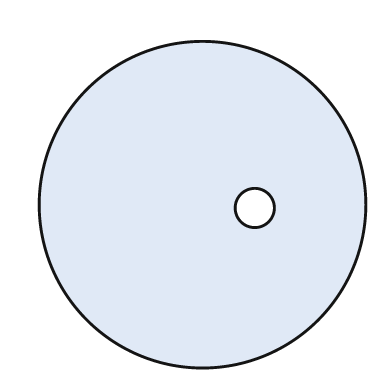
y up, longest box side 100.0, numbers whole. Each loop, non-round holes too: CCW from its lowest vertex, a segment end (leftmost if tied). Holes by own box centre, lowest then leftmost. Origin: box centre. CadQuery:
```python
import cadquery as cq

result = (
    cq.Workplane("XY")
    .moveTo(0.0, 0.0)
    .circle(50.0)
    .moveTo(16.0, -1.0)
    .circle(6.0)
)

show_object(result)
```